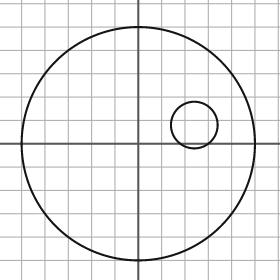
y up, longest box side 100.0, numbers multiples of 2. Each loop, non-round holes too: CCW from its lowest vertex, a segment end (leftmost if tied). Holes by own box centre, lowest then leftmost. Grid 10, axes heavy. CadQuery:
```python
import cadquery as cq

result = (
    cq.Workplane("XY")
    .moveTo(0.0, 0.0)
    .circle(50.0)
    .moveTo(24.0, 8.0)
    .circle(10.0)
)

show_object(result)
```